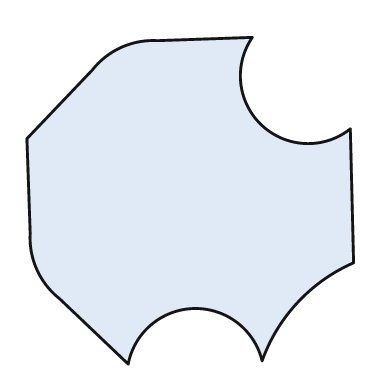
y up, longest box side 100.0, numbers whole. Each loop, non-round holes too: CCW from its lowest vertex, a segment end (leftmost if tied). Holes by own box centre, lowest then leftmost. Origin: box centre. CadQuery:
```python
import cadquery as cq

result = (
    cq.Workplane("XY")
    .moveTo(-19.0, -50.0)
    .threePointArc((1.0, -33.0), (22.0, -49.0))
    .threePointArc((33.0, -31.0), (50.0, -19.0))
    .lineTo(49.0, 22.0)
    .threePointArc((22.0, 23.0), (19.0, 50.0))
    .lineTo(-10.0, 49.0)
    .threePointArc((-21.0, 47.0), (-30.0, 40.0))
    .lineTo(-50.0, 19.0)
    .lineTo(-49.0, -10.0)
    .threePointArc((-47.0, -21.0), (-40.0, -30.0))
    .close()
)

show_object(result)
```